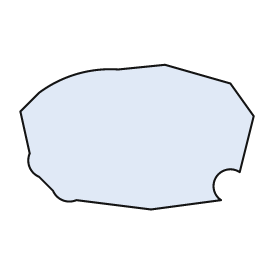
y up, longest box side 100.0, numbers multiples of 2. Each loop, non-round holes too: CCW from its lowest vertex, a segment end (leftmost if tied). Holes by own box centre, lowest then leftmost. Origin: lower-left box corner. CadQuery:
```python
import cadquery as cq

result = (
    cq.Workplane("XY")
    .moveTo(56.0, 0.0)
    .lineTo(86.0, 4.0)
    .threePointArc((84.0, 14.0), (94.0, 16.0))
    .lineTo(100.0, 40.0)
    .lineTo(90.0, 54.0)
    .lineTo(62.0, 62.0)
    .lineTo(42.0, 60.0)
    .threePointArc((24.0, 58.0), (8.0, 50.0))
    .lineTo(0.0, 42.0)
    .lineTo(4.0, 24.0)
    .threePointArc((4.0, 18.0), (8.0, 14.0))
    .lineTo(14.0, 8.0)
    .threePointArc((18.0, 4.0), (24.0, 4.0))
    .close()
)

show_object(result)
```